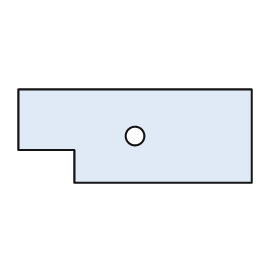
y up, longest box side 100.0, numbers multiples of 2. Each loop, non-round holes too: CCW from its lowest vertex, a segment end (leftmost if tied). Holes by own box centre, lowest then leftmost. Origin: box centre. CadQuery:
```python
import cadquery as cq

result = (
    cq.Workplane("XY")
    .moveTo(-26.0, -20.0)
    .lineTo(50.0, -20.0)
    .lineTo(50.0, 20.0)
    .lineTo(-50.0, 20.0)
    .lineTo(-50.0, -6.0)
    .lineTo(-26.0, -6.0)
    .close()
    .moveTo(0.0, 0.0)
    .circle(4.0)
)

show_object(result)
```